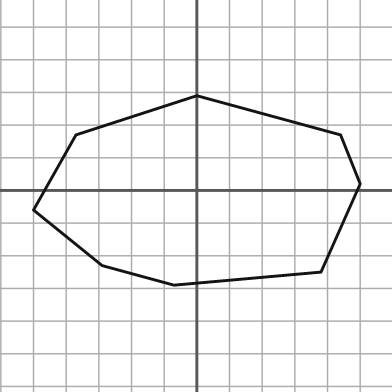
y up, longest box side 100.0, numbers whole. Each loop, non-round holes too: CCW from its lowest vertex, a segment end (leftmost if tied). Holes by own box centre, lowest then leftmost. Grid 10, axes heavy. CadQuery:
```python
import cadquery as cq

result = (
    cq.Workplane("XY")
    .moveTo(-7.0, -29.0)
    .lineTo(38.0, -25.0)
    .lineTo(50.0, 2.0)
    .lineTo(44.0, 17.0)
    .lineTo(0.0, 29.0)
    .lineTo(-37.0, 17.0)
    .lineTo(-50.0, -6.0)
    .lineTo(-29.0, -23.0)
    .close()
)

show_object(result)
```